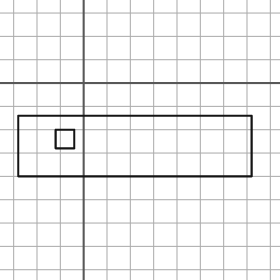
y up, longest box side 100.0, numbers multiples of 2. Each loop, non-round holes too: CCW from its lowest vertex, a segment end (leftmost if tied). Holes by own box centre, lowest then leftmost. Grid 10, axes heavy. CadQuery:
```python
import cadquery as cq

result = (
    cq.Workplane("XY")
    .moveTo(-28.0, -40.0)
    .lineTo(72.0, -40.0)
    .lineTo(72.0, -14.0)
    .lineTo(-28.0, -14.0)
    .close()
    .moveTo(-12.0, -28.0)
    .lineTo(-4.0, -28.0)
    .lineTo(-4.0, -20.0)
    .lineTo(-12.0, -20.0)
    .close()
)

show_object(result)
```